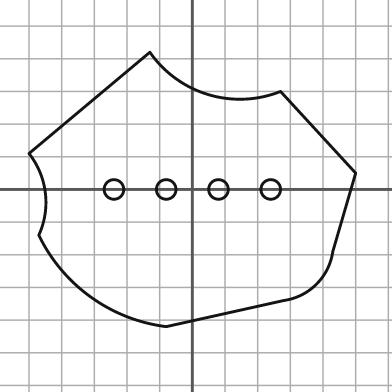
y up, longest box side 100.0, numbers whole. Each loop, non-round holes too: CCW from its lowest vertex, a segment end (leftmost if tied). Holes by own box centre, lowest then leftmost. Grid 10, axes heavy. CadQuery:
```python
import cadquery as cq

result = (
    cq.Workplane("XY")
    .moveTo(-8.0, -42.0)
    .lineTo(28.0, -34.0)
    .threePointArc((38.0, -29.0), (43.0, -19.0))
    .lineTo(50.0, 5.0)
    .lineTo(27.0, 30.0)
    .threePointArc((5.0, 29.0), (-13.0, 42.0))
    .lineTo(-50.0, 11.0)
    .threePointArc((-45.0, -1.0), (-47.0, -14.0))
    .threePointArc((-31.0, -33.0), (-8.0, -42.0))
    .close()
    .moveTo(-24.0, 0.0)
    .circle(3.0)
    .moveTo(-8.0, 0.0)
    .circle(3.0)
    .moveTo(8.0, 0.0)
    .circle(3.0)
    .moveTo(24.0, 0.0)
    .circle(3.0)
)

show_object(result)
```